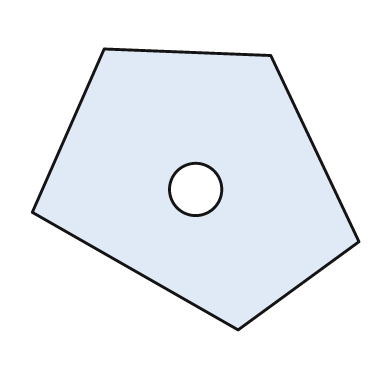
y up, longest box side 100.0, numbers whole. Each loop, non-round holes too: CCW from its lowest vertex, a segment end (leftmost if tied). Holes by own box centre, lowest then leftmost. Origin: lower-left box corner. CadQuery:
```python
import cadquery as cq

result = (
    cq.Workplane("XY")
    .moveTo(63.0, 0.0)
    .lineTo(100.0, 27.0)
    .lineTo(73.0, 84.0)
    .lineTo(22.0, 86.0)
    .lineTo(0.0, 36.0)
    .close()
    .moveTo(50.0, 43.0)
    .circle(8.0)
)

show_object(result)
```